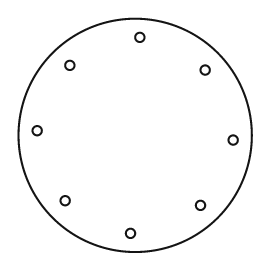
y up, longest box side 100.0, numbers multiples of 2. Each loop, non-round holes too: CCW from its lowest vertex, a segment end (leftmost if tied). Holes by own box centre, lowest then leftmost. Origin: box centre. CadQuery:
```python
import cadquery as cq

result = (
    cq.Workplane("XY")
    .moveTo(0.0, 0.0)
    .circle(50.0)
    .moveTo(-2.0, -42.0)
    .circle(2.0)
    .moveTo(28.0, -30.0)
    .circle(2.0)
    .moveTo(-30.0, -28.0)
    .circle(2.0)
    .moveTo(42.0, -2.0)
    .circle(2.0)
    .moveTo(-42.0, 2.0)
    .circle(2.0)
    .moveTo(30.0, 28.0)
    .circle(2.0)
    .moveTo(-28.0, 30.0)
    .circle(2.0)
    .moveTo(2.0, 42.0)
    .circle(2.0)
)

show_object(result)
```